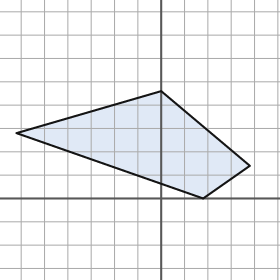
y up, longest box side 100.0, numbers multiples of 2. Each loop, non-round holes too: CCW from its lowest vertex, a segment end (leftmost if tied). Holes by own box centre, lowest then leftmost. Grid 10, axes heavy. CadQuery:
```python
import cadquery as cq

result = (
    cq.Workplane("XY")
    .moveTo(18.0, 0.0)
    .lineTo(38.0, 14.0)
    .lineTo(0.0, 46.0)
    .lineTo(-62.0, 28.0)
    .close()
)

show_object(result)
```